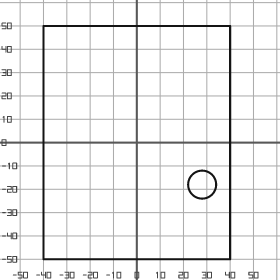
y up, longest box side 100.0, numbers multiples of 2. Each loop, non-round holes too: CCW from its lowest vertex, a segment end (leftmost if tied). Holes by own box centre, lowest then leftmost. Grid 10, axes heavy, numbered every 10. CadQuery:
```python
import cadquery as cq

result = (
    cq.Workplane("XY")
    .moveTo(-40.0, -50.0)
    .lineTo(40.0, -50.0)
    .lineTo(40.0, 50.0)
    .lineTo(-40.0, 50.0)
    .close()
    .moveTo(28.0, -18.0)
    .circle(6.0)
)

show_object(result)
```